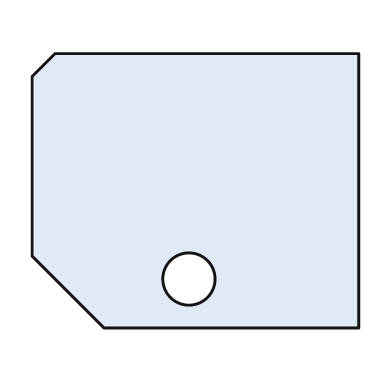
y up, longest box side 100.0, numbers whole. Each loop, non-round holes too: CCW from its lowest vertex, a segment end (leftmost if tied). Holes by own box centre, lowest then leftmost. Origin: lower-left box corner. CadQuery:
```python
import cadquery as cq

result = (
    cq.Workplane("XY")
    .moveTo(22.0, 0.0)
    .lineTo(100.0, 0.0)
    .lineTo(100.0, 84.0)
    .lineTo(7.0, 84.0)
    .lineTo(0.0, 77.0)
    .lineTo(0.0, 22.0)
    .close()
    .moveTo(48.0, 15.0)
    .circle(8.0)
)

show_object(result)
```